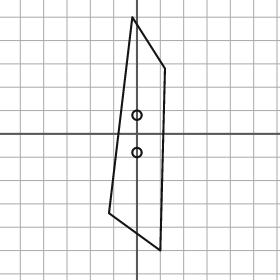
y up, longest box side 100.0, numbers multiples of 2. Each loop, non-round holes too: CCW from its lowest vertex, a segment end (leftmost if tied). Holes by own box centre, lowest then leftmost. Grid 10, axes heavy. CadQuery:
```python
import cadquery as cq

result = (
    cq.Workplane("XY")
    .moveTo(10.0, -50.0)
    .lineTo(12.0, 28.0)
    .lineTo(-2.0, 50.0)
    .lineTo(-12.0, -34.0)
    .close()
    .moveTo(0.0, -8.0)
    .circle(2.0)
    .moveTo(0.0, 8.0)
    .circle(2.0)
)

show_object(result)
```